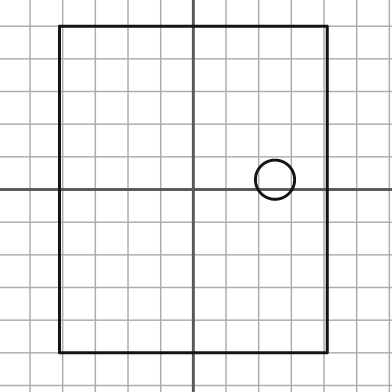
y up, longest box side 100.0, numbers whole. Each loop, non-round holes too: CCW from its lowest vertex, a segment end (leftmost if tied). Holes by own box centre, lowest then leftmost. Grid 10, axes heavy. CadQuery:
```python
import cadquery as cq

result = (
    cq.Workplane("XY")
    .moveTo(-41.0, -50.0)
    .lineTo(41.0, -50.0)
    .lineTo(41.0, 50.0)
    .lineTo(-41.0, 50.0)
    .close()
    .moveTo(25.0, 3.0)
    .circle(6.0)
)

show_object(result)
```